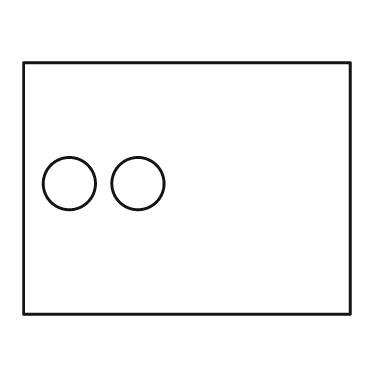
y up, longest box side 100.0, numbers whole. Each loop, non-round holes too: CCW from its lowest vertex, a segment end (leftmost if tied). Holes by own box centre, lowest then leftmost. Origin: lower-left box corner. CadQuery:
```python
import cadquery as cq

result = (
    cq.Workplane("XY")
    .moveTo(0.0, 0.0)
    .lineTo(100.0, 0.0)
    .lineTo(100.0, 77.0)
    .lineTo(0.0, 77.0)
    .close()
    .moveTo(14.0, 40.0)
    .circle(8.0)
    .moveTo(35.0, 40.0)
    .circle(8.0)
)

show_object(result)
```